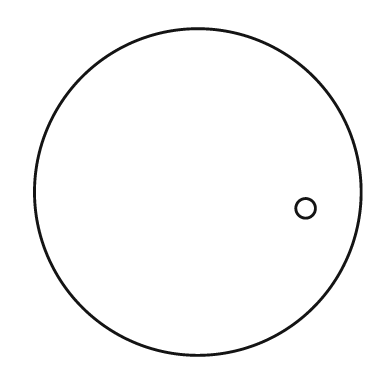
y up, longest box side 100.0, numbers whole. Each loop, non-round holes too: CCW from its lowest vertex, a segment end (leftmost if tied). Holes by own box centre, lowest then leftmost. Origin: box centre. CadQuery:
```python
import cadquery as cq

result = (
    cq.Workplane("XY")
    .moveTo(0.0, 0.0)
    .circle(50.0)
    .moveTo(33.0, -5.0)
    .circle(3.0)
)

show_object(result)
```